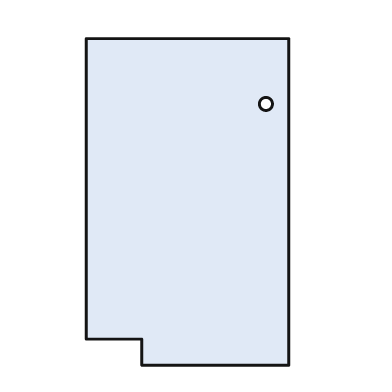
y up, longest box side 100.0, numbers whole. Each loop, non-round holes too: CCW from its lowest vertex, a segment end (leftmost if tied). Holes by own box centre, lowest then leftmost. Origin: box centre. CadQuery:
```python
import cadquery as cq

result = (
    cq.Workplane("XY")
    .moveTo(-14.0, -50.0)
    .lineTo(31.0, -50.0)
    .lineTo(31.0, 50.0)
    .lineTo(-31.0, 50.0)
    .lineTo(-31.0, -42.0)
    .lineTo(-14.0, -42.0)
    .close()
    .moveTo(24.0, 30.0)
    .circle(2.0)
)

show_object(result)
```